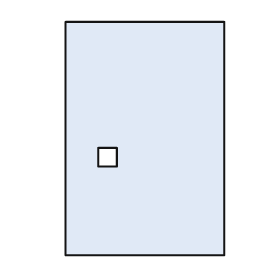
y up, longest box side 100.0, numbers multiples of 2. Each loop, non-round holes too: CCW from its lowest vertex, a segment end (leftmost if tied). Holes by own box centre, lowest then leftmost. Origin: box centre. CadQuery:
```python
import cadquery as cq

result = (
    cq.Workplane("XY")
    .moveTo(-34.0, -50.0)
    .lineTo(34.0, -50.0)
    .lineTo(34.0, 50.0)
    .lineTo(-34.0, 50.0)
    .close()
    .moveTo(-20.0, -12.0)
    .lineTo(-12.0, -12.0)
    .lineTo(-12.0, -4.0)
    .lineTo(-20.0, -4.0)
    .close()
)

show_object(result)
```